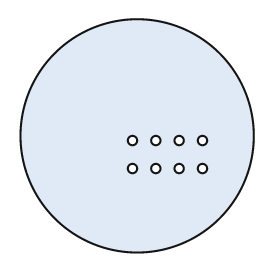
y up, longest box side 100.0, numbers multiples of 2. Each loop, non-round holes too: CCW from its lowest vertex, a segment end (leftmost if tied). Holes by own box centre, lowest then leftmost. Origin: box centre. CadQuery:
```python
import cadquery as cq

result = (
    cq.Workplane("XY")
    .moveTo(0.0, 0.0)
    .circle(50.0)
    .moveTo(-2.0, -14.0)
    .circle(2.0)
    .moveTo(8.0, -14.0)
    .circle(2.0)
    .moveTo(18.0, -14.0)
    .circle(2.0)
    .moveTo(28.0, -14.0)
    .circle(2.0)
    .moveTo(-2.0, -2.0)
    .circle(2.0)
    .moveTo(8.0, -2.0)
    .circle(2.0)
    .moveTo(18.0, -2.0)
    .circle(2.0)
    .moveTo(28.0, -2.0)
    .circle(2.0)
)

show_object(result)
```